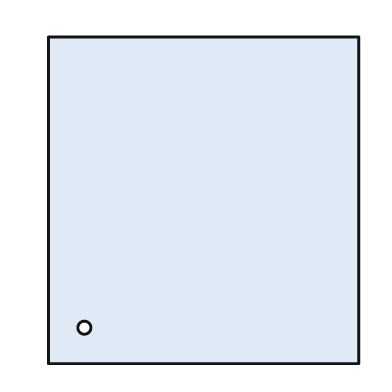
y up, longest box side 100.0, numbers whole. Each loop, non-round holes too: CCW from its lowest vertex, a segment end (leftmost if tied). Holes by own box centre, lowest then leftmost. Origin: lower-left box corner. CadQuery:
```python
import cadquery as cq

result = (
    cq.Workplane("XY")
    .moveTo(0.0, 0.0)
    .lineTo(95.0, 0.0)
    .lineTo(95.0, 100.0)
    .lineTo(0.0, 100.0)
    .close()
    .moveTo(11.0, 11.0)
    .circle(2.0)
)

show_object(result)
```